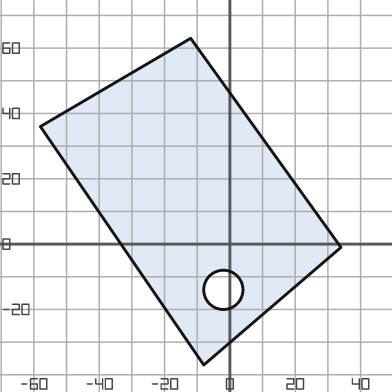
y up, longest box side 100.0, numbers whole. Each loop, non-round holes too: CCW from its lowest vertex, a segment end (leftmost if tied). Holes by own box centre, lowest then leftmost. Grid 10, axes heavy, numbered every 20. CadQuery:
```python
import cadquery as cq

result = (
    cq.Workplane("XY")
    .moveTo(-8.0, -37.0)
    .lineTo(34.0, -1.0)
    .lineTo(-12.0, 63.0)
    .lineTo(-58.0, 36.0)
    .close()
    .moveTo(-2.0, -14.0)
    .circle(6.0)
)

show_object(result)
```